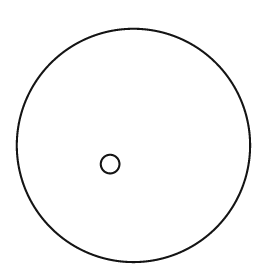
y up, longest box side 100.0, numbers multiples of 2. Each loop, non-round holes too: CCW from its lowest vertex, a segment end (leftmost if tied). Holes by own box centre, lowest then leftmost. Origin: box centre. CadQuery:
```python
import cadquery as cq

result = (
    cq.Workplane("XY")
    .moveTo(0.0, 0.0)
    .circle(50.0)
    .moveTo(-10.0, -8.0)
    .circle(4.0)
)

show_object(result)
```